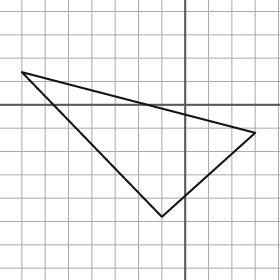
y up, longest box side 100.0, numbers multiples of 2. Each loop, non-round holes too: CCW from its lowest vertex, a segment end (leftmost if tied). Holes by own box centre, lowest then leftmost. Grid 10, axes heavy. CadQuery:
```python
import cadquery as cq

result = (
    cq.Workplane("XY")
    .moveTo(-10.0, -48.0)
    .lineTo(30.0, -12.0)
    .lineTo(-70.0, 14.0)
    .close()
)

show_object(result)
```